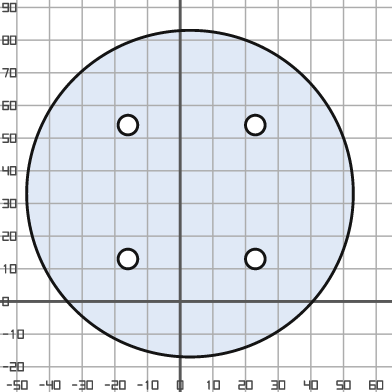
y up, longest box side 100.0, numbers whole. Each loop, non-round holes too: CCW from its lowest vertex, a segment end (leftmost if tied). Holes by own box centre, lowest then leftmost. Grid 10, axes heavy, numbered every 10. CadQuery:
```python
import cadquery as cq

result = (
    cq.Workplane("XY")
    .moveTo(3.0, 33.0)
    .circle(50.0)
    .moveTo(-16.0, 13.0)
    .circle(3.0)
    .moveTo(23.0, 13.0)
    .circle(3.0)
    .moveTo(-16.0, 54.0)
    .circle(3.0)
    .moveTo(23.0, 54.0)
    .circle(3.0)
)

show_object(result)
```